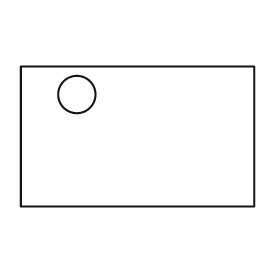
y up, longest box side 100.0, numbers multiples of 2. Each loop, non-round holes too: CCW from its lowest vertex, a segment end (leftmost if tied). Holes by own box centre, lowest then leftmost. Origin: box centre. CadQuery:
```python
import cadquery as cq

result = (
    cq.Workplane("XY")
    .moveTo(-50.0, -30.0)
    .lineTo(50.0, -30.0)
    .lineTo(50.0, 30.0)
    .lineTo(-50.0, 30.0)
    .close()
    .moveTo(-26.0, 18.0)
    .circle(8.0)
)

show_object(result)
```